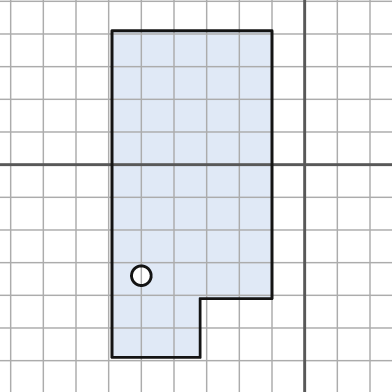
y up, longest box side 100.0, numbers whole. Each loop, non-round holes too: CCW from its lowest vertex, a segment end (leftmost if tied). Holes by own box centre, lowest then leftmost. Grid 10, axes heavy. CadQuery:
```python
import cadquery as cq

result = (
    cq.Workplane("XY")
    .moveTo(-59.0, -59.0)
    .lineTo(-32.0, -59.0)
    .lineTo(-32.0, -41.0)
    .lineTo(-10.0, -41.0)
    .lineTo(-10.0, 41.0)
    .lineTo(-59.0, 41.0)
    .close()
    .moveTo(-50.0, -34.0)
    .circle(3.0)
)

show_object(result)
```